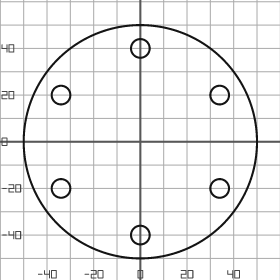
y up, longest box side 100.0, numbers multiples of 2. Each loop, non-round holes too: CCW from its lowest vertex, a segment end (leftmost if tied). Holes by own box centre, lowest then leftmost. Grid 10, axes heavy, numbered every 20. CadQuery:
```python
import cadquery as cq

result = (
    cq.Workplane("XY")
    .moveTo(0.0, 0.0)
    .circle(50.0)
    .moveTo(0.0, -40.0)
    .circle(4.0)
    .moveTo(-34.0, -20.0)
    .circle(4.0)
    .moveTo(34.0, -20.0)
    .circle(4.0)
    .moveTo(-34.0, 20.0)
    .circle(4.0)
    .moveTo(34.0, 20.0)
    .circle(4.0)
    .moveTo(0.0, 40.0)
    .circle(4.0)
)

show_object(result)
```